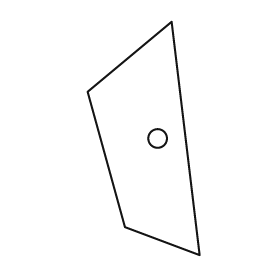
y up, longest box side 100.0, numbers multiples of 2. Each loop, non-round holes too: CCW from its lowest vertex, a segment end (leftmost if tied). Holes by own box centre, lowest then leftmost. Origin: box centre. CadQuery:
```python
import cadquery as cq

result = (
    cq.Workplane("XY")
    .moveTo(24.0, -50.0)
    .lineTo(12.0, 50.0)
    .lineTo(-24.0, 20.0)
    .lineTo(-8.0, -38.0)
    .close()
    .moveTo(6.0, 0.0)
    .circle(4.0)
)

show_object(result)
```